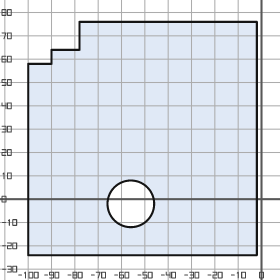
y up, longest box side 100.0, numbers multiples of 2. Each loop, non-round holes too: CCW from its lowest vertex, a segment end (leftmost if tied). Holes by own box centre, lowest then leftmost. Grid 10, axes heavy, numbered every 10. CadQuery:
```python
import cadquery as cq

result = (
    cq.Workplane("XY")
    .moveTo(-100.0, -24.0)
    .lineTo(-2.0, -24.0)
    .lineTo(-2.0, 76.0)
    .lineTo(-78.0, 76.0)
    .lineTo(-78.0, 64.0)
    .lineTo(-90.0, 64.0)
    .lineTo(-90.0, 58.0)
    .lineTo(-100.0, 58.0)
    .close()
    .moveTo(-56.0, -2.0)
    .circle(10.0)
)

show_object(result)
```